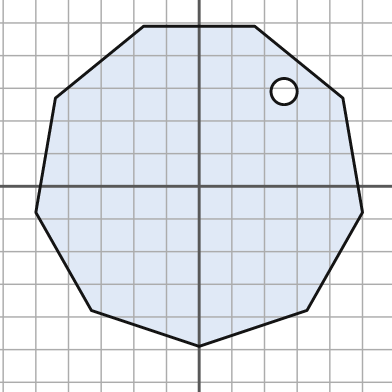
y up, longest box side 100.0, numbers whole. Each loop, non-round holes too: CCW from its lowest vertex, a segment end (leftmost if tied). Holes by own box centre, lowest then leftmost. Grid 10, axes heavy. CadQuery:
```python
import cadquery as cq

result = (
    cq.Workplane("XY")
    .moveTo(0.0, -49.0)
    .lineTo(33.0, -38.0)
    .lineTo(50.0, -8.0)
    .lineTo(44.0, 27.0)
    .lineTo(17.0, 49.0)
    .lineTo(-17.0, 49.0)
    .lineTo(-44.0, 27.0)
    .lineTo(-50.0, -8.0)
    .lineTo(-33.0, -38.0)
    .close()
    .moveTo(26.0, 29.0)
    .circle(4.0)
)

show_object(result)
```